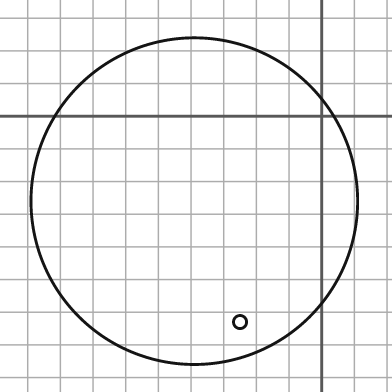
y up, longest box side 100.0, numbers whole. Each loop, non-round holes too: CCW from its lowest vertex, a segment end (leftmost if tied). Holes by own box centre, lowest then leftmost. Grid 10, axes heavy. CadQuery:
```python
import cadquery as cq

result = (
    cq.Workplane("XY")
    .moveTo(-39.0, -26.0)
    .circle(50.0)
    .moveTo(-25.0, -63.0)
    .circle(2.0)
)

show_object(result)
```